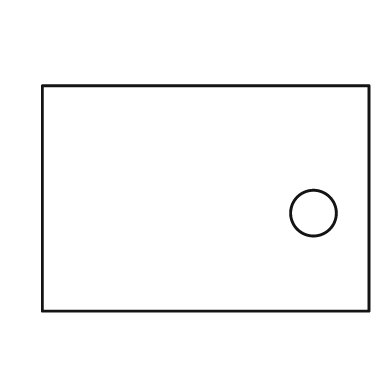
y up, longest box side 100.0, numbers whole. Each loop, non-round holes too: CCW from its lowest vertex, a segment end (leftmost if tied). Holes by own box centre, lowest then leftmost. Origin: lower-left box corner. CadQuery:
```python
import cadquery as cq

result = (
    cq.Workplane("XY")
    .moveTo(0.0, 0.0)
    .lineTo(100.0, 0.0)
    .lineTo(100.0, 69.0)
    .lineTo(0.0, 69.0)
    .close()
    .moveTo(83.0, 30.0)
    .circle(7.0)
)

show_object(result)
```